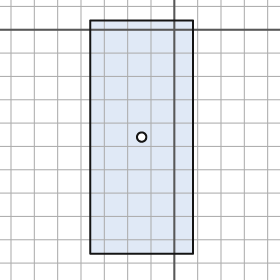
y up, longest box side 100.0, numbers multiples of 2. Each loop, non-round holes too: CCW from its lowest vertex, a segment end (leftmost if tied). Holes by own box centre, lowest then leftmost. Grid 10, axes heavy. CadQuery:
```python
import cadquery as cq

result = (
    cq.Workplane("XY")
    .moveTo(-36.0, -96.0)
    .lineTo(8.0, -96.0)
    .lineTo(8.0, 4.0)
    .lineTo(-36.0, 4.0)
    .close()
    .moveTo(-14.0, -46.0)
    .circle(2.0)
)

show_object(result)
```